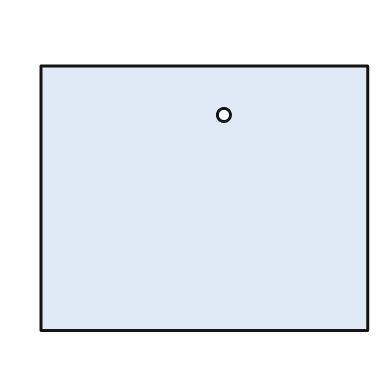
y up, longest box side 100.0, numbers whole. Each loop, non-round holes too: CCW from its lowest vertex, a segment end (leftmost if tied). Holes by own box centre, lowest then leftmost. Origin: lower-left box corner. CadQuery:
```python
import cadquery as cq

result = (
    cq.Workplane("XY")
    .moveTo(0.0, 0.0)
    .lineTo(100.0, 0.0)
    .lineTo(100.0, 81.0)
    .lineTo(0.0, 81.0)
    .close()
    .moveTo(56.0, 66.0)
    .circle(2.0)
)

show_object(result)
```